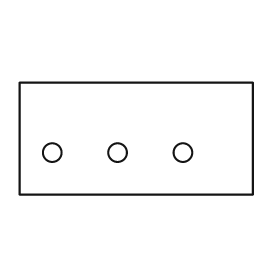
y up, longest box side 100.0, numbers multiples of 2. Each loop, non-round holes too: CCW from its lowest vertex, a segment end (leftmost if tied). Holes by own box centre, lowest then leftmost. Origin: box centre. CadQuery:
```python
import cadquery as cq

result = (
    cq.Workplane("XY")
    .moveTo(-50.0, -24.0)
    .lineTo(50.0, -24.0)
    .lineTo(50.0, 24.0)
    .lineTo(-50.0, 24.0)
    .close()
    .moveTo(-36.0, -6.0)
    .circle(4.0)
    .moveTo(-8.0, -6.0)
    .circle(4.0)
    .moveTo(20.0, -6.0)
    .circle(4.0)
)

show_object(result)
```